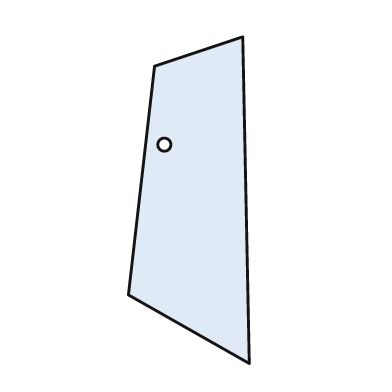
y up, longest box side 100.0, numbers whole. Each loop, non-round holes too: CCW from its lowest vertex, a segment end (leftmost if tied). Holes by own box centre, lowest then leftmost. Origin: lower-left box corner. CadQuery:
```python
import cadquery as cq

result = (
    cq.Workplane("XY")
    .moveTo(37.0, 0.0)
    .lineTo(35.0, 100.0)
    .lineTo(8.0, 91.0)
    .lineTo(0.0, 21.0)
    .close()
    .moveTo(11.0, 67.0)
    .circle(2.0)
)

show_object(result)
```